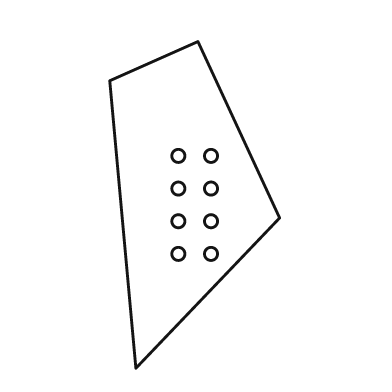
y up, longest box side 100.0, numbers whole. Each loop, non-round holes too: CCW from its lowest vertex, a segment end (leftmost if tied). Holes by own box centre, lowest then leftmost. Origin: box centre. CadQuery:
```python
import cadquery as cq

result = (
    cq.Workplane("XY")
    .moveTo(-18.0, -50.0)
    .lineTo(26.0, -4.0)
    .lineTo(1.0, 50.0)
    .lineTo(-26.0, 38.0)
    .close()
    .moveTo(-5.0, -15.0)
    .circle(2.0)
    .moveTo(5.0, -15.0)
    .circle(2.0)
    .moveTo(-5.0, -5.0)
    .circle(2.0)
    .moveTo(5.0, -5.0)
    .circle(2.0)
    .moveTo(-5.0, 5.0)
    .circle(2.0)
    .moveTo(5.0, 5.0)
    .circle(2.0)
    .moveTo(-5.0, 15.0)
    .circle(2.0)
    .moveTo(5.0, 15.0)
    .circle(2.0)
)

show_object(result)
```